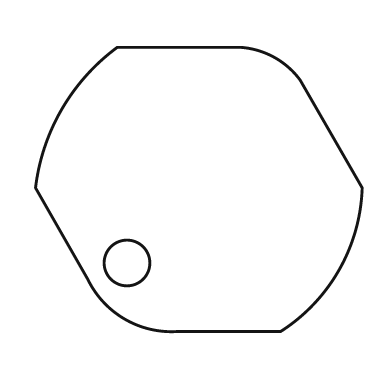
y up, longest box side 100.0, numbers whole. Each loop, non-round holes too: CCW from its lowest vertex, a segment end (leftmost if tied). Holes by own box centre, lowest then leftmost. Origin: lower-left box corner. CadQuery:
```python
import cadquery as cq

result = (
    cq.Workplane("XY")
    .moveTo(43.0, 0.0)
    .lineTo(75.0, 0.0)
    .threePointArc((93.0, 19.0), (100.0, 44.0))
    .lineTo(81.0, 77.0)
    .threePointArc((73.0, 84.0), (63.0, 87.0))
    .lineTo(25.0, 87.0)
    .threePointArc((8.0, 68.0), (0.0, 44.0))
    .lineTo(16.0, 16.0)
    .threePointArc((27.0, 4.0), (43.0, 0.0))
    .close()
    .moveTo(28.0, 21.0)
    .circle(7.0)
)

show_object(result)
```